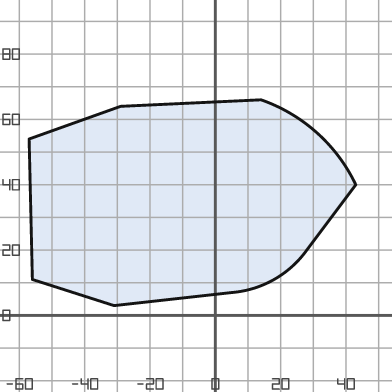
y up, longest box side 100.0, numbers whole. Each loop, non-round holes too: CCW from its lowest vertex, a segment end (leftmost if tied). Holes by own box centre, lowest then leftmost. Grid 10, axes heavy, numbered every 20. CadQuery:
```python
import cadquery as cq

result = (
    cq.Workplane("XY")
    .moveTo(-31.0, 3.0)
    .lineTo(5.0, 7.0)
    .threePointArc((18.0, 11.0), (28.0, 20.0))
    .lineTo(43.0, 40.0)
    .threePointArc((31.0, 56.0), (14.0, 66.0))
    .lineTo(-29.0, 64.0)
    .lineTo(-57.0, 54.0)
    .lineTo(-56.0, 11.0)
    .close()
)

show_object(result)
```